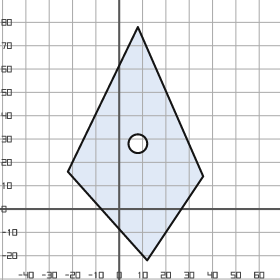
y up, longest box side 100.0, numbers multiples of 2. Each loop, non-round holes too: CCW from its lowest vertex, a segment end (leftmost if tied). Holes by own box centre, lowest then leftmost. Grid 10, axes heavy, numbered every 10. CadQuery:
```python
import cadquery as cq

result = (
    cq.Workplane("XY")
    .moveTo(12.0, -22.0)
    .lineTo(36.0, 14.0)
    .lineTo(8.0, 78.0)
    .lineTo(-22.0, 16.0)
    .close()
    .moveTo(8.0, 28.0)
    .circle(4.0)
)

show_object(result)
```